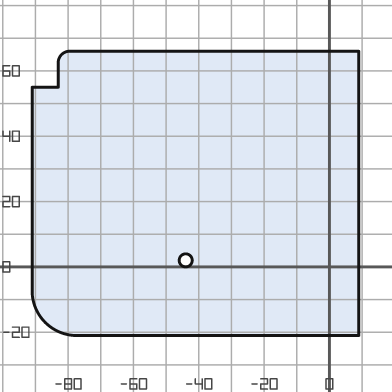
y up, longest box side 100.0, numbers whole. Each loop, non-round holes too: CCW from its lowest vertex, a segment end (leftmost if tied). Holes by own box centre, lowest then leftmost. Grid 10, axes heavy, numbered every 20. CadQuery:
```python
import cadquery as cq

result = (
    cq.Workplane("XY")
    .moveTo(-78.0, -21.0)
    .lineTo(9.0, -21.0)
    .lineTo(9.0, 66.0)
    .lineTo(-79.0, 66.0)
    .threePointArc((-82.0, 65.0), (-83.0, 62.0))
    .lineTo(-83.0, 55.0)
    .lineTo(-91.0, 55.0)
    .lineTo(-91.0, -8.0)
    .threePointArc((-87.0, -17.0), (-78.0, -21.0))
    .close()
    .moveTo(-44.0, 2.0)
    .circle(2.0)
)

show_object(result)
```